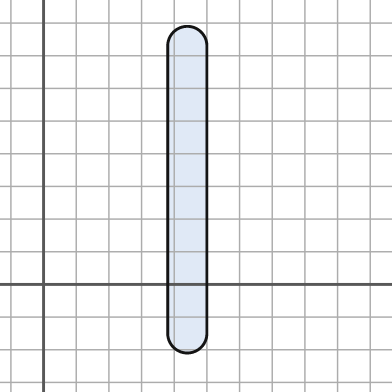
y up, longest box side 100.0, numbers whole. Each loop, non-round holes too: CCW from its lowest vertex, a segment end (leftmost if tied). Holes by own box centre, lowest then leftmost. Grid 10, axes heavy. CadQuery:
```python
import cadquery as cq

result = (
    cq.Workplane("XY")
    .moveTo(38.0, -15.0)
    .threePointArc((44.0, -21.0), (50.0, -15.0))
    .lineTo(50.0, 73.0)
    .threePointArc((44.0, 79.0), (38.0, 73.0))
    .close()
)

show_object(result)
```